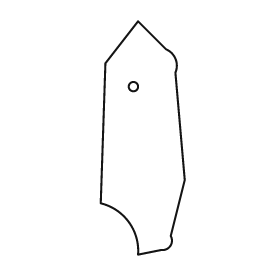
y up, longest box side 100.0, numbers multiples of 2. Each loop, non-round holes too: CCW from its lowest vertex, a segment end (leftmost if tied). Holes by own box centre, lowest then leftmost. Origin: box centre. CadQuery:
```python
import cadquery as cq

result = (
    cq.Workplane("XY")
    .moveTo(-2.0, -50.0)
    .lineTo(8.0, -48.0)
    .threePointArc((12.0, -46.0), (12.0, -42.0))
    .lineTo(18.0, -18.0)
    .lineTo(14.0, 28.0)
    .threePointArc((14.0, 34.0), (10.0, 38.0))
    .lineTo(-2.0, 50.0)
    .lineTo(-16.0, 32.0)
    .lineTo(-18.0, -28.0)
    .threePointArc((-6.0, -36.0), (-2.0, -50.0))
    .close()
    .moveTo(-4.0, 22.0)
    .circle(2.0)
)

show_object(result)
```